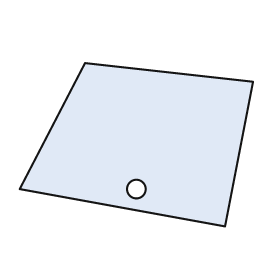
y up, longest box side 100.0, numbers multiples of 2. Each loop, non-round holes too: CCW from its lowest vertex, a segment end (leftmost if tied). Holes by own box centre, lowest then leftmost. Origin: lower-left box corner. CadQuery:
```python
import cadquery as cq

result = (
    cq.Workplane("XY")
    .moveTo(88.0, 0.0)
    .lineTo(100.0, 62.0)
    .lineTo(28.0, 70.0)
    .lineTo(0.0, 16.0)
    .close()
    .moveTo(50.0, 16.0)
    .circle(4.0)
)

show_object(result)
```